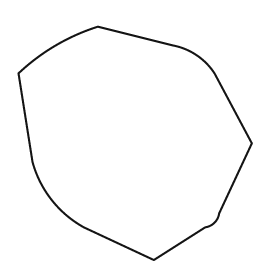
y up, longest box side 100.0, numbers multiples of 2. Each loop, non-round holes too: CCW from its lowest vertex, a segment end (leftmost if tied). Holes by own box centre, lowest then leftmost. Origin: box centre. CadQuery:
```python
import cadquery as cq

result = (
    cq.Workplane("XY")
    .moveTo(8.0, -50.0)
    .lineTo(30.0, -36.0)
    .threePointArc((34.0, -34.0), (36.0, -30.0))
    .lineTo(50.0, 0.0)
    .lineTo(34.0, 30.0)
    .threePointArc((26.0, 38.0), (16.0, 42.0))
    .lineTo(-16.0, 50.0)
    .threePointArc((-34.0, 42.0), (-50.0, 30.0))
    .lineTo(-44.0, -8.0)
    .threePointArc((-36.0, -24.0), (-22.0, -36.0))
    .close()
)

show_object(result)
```